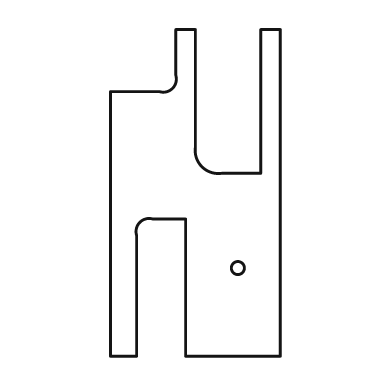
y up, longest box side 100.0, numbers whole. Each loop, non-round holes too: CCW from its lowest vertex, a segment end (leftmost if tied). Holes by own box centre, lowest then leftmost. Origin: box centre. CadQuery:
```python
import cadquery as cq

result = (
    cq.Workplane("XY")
    .moveTo(-26.0, -50.0)
    .lineTo(-18.0, -50.0)
    .lineTo(-18.0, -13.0)
    .threePointArc((-17.0, -9.0), (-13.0, -8.0))
    .lineTo(-3.0, -8.0)
    .lineTo(-3.0, -50.0)
    .lineTo(26.0, -50.0)
    .lineTo(26.0, 50.0)
    .lineTo(20.0, 50.0)
    .lineTo(20.0, 6.0)
    .lineTo(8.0, 6.0)
    .threePointArc((2.0, 8.0), (0.0, 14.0))
    .lineTo(0.0, 50.0)
    .lineTo(-6.0, 50.0)
    .lineTo(-6.0, 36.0)
    .threePointArc((-7.0, 32.0), (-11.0, 31.0))
    .lineTo(-26.0, 31.0)
    .close()
    .moveTo(13.0, -23.0)
    .circle(2.0)
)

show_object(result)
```